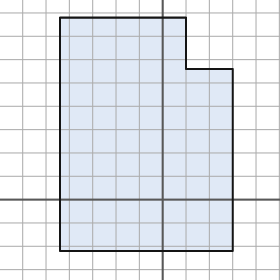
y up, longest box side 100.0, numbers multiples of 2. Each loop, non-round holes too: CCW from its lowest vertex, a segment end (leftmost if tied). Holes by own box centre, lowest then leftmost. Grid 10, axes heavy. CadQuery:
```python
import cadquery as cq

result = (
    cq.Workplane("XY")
    .moveTo(-44.0, -22.0)
    .lineTo(30.0, -22.0)
    .lineTo(30.0, 56.0)
    .lineTo(10.0, 56.0)
    .lineTo(10.0, 78.0)
    .lineTo(-44.0, 78.0)
    .close()
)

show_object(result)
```